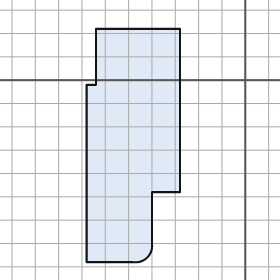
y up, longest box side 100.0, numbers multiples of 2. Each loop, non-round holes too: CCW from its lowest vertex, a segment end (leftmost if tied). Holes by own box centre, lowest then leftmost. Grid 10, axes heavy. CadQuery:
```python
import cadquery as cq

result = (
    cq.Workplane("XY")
    .moveTo(-68.0, -78.0)
    .lineTo(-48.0, -78.0)
    .threePointArc((-42.0, -76.0), (-40.0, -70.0))
    .lineTo(-40.0, -48.0)
    .lineTo(-28.0, -48.0)
    .lineTo(-28.0, 22.0)
    .lineTo(-64.0, 22.0)
    .lineTo(-64.0, -2.0)
    .lineTo(-68.0, -2.0)
    .close()
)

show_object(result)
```